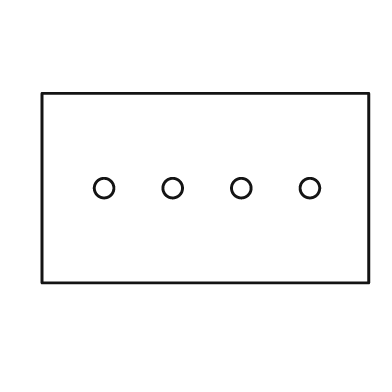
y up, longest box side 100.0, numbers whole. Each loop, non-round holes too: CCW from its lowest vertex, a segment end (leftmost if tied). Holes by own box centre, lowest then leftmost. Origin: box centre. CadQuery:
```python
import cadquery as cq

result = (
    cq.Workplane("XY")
    .moveTo(-50.0, -29.0)
    .lineTo(50.0, -29.0)
    .lineTo(50.0, 29.0)
    .lineTo(-50.0, 29.0)
    .close()
    .moveTo(-31.0, 0.0)
    .circle(3.0)
    .moveTo(-10.0, 0.0)
    .circle(3.0)
    .moveTo(11.0, 0.0)
    .circle(3.0)
    .moveTo(32.0, 0.0)
    .circle(3.0)
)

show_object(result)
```